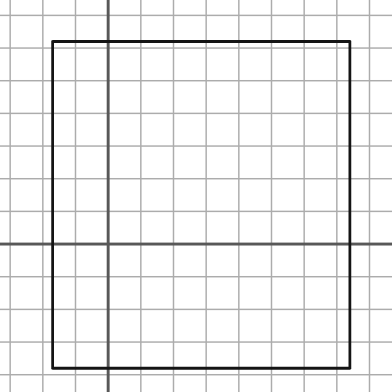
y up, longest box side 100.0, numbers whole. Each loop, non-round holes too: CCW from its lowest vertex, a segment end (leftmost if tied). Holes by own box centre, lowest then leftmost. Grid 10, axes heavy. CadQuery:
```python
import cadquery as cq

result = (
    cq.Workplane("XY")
    .moveTo(-17.0, -38.0)
    .lineTo(74.0, -38.0)
    .lineTo(74.0, 62.0)
    .lineTo(-17.0, 62.0)
    .close()
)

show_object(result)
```